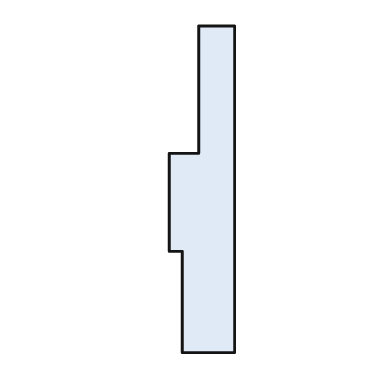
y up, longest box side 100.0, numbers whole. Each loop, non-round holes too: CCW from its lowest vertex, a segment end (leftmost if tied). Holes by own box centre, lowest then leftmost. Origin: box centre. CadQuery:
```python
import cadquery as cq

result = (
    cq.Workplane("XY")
    .moveTo(-6.0, -50.0)
    .lineTo(10.0, -50.0)
    .lineTo(10.0, 50.0)
    .lineTo(-1.0, 50.0)
    .lineTo(-1.0, 11.0)
    .lineTo(-10.0, 11.0)
    .lineTo(-10.0, -19.0)
    .lineTo(-6.0, -19.0)
    .close()
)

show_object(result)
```